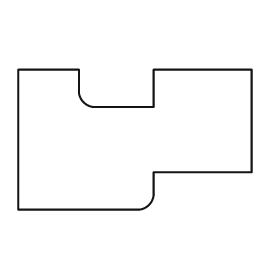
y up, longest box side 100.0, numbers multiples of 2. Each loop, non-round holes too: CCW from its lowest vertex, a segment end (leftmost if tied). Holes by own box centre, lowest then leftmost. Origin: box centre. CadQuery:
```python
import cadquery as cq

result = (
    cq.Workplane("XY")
    .moveTo(-50.0, -30.0)
    .lineTo(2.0, -30.0)
    .threePointArc((6.0, -28.0), (8.0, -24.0))
    .lineTo(8.0, -14.0)
    .lineTo(50.0, -14.0)
    .lineTo(50.0, 30.0)
    .lineTo(8.0, 30.0)
    .lineTo(8.0, 14.0)
    .lineTo(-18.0, 14.0)
    .threePointArc((-22.0, 16.0), (-24.0, 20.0))
    .lineTo(-24.0, 30.0)
    .lineTo(-50.0, 30.0)
    .close()
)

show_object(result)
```